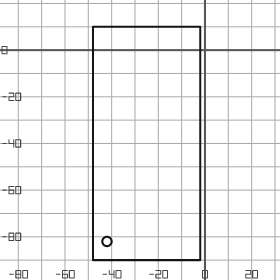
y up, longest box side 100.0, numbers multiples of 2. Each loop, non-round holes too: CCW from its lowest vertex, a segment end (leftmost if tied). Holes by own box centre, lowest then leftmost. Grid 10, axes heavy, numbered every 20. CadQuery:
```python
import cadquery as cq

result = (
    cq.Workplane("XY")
    .moveTo(-48.0, -90.0)
    .lineTo(-2.0, -90.0)
    .lineTo(-2.0, 10.0)
    .lineTo(-48.0, 10.0)
    .close()
    .moveTo(-42.0, -82.0)
    .circle(2.0)
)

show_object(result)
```